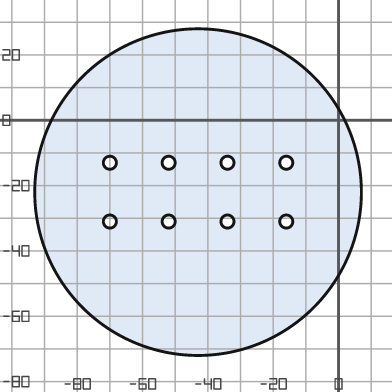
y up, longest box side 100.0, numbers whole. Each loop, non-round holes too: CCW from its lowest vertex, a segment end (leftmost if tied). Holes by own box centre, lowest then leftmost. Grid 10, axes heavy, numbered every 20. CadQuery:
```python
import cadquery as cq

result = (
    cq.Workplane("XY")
    .moveTo(-43.0, -22.0)
    .circle(50.0)
    .moveTo(-70.0, -31.0)
    .circle(2.0)
    .moveTo(-52.0, -31.0)
    .circle(2.0)
    .moveTo(-34.0, -31.0)
    .circle(2.0)
    .moveTo(-16.0, -31.0)
    .circle(2.0)
    .moveTo(-70.0, -13.0)
    .circle(2.0)
    .moveTo(-52.0, -13.0)
    .circle(2.0)
    .moveTo(-34.0, -13.0)
    .circle(2.0)
    .moveTo(-16.0, -13.0)
    .circle(2.0)
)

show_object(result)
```